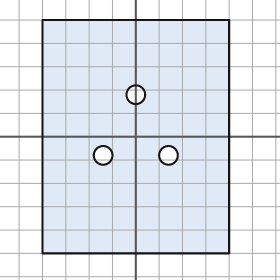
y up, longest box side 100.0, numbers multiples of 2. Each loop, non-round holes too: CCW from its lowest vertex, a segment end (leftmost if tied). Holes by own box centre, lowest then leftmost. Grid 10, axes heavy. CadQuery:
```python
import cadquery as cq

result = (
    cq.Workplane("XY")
    .moveTo(-40.0, -50.0)
    .lineTo(40.0, -50.0)
    .lineTo(40.0, 50.0)
    .lineTo(-40.0, 50.0)
    .close()
    .moveTo(-14.0, -8.0)
    .circle(4.0)
    .moveTo(14.0, -8.0)
    .circle(4.0)
    .moveTo(0.0, 18.0)
    .circle(4.0)
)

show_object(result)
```